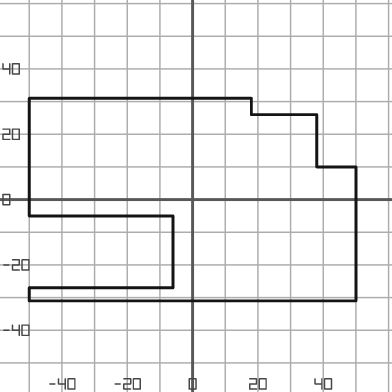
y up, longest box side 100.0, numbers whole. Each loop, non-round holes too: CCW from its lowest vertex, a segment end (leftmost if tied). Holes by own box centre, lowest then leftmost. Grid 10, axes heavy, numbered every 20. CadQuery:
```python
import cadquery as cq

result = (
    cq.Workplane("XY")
    .moveTo(-50.0, -31.0)
    .lineTo(50.0, -31.0)
    .lineTo(50.0, 10.0)
    .lineTo(38.0, 10.0)
    .lineTo(38.0, 26.0)
    .lineTo(18.0, 26.0)
    .lineTo(18.0, 31.0)
    .lineTo(-50.0, 31.0)
    .lineTo(-50.0, -5.0)
    .lineTo(-6.0, -5.0)
    .lineTo(-6.0, -27.0)
    .lineTo(-50.0, -27.0)
    .close()
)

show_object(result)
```